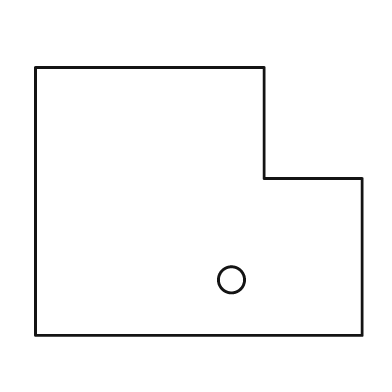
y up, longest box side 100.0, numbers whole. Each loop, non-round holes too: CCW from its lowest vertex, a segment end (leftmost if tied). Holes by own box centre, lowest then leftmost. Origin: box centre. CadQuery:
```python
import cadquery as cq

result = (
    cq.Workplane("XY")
    .moveTo(-50.0, -41.0)
    .lineTo(50.0, -41.0)
    .lineTo(50.0, 7.0)
    .lineTo(20.0, 7.0)
    .lineTo(20.0, 41.0)
    .lineTo(-50.0, 41.0)
    .close()
    .moveTo(10.0, -24.0)
    .circle(4.0)
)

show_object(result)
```